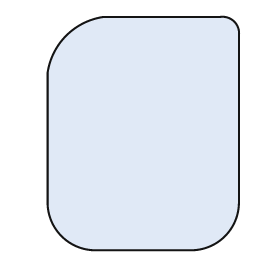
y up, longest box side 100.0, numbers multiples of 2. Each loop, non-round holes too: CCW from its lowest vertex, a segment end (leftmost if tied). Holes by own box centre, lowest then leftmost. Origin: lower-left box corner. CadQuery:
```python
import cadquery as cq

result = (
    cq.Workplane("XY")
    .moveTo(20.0, 0.0)
    .lineTo(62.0, 0.0)
    .threePointArc((76.0, 6.0), (82.0, 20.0))
    .lineTo(82.0, 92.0)
    .threePointArc((80.0, 98.0), (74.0, 100.0))
    .lineTo(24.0, 100.0)
    .threePointArc((8.0, 92.0), (0.0, 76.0))
    .lineTo(0.0, 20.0)
    .threePointArc((6.0, 6.0), (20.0, 0.0))
    .close()
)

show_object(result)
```